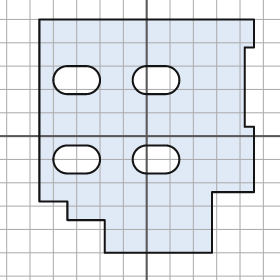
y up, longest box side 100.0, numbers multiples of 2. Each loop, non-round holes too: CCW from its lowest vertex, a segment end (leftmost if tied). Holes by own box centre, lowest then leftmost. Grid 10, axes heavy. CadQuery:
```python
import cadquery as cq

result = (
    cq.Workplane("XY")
    .moveTo(-18.0, -50.0)
    .lineTo(28.0, -50.0)
    .lineTo(28.0, -24.0)
    .lineTo(46.0, -24.0)
    .lineTo(46.0, 4.0)
    .lineTo(42.0, 4.0)
    .lineTo(42.0, 38.0)
    .lineTo(46.0, 38.0)
    .lineTo(46.0, 50.0)
    .lineTo(-46.0, 50.0)
    .lineTo(-46.0, -28.0)
    .lineTo(-34.0, -28.0)
    .lineTo(-34.0, -36.0)
    .lineTo(-18.0, -36.0)
    .close()
    .moveTo(-34.0, -16.0)
    .lineTo(-26.0, -16.0)
    .threePointArc((-20.0, -10.0), (-26.0, -4.0))
    .lineTo(-34.0, -4.0)
    .threePointArc((-40.0, -10.0), (-34.0, -16.0))
    .close()
    .moveTo(0.0, -16.0)
    .lineTo(8.0, -16.0)
    .threePointArc((14.0, -10.0), (8.0, -4.0))
    .lineTo(0.0, -4.0)
    .threePointArc((-6.0, -10.0), (0.0, -16.0))
    .close()
    .moveTo(-34.0, 18.0)
    .lineTo(-26.0, 18.0)
    .threePointArc((-20.0, 24.0), (-26.0, 30.0))
    .lineTo(-34.0, 30.0)
    .threePointArc((-40.0, 24.0), (-34.0, 18.0))
    .close()
    .moveTo(0.0, 18.0)
    .lineTo(8.0, 18.0)
    .threePointArc((14.0, 24.0), (8.0, 30.0))
    .lineTo(0.0, 30.0)
    .threePointArc((-6.0, 24.0), (0.0, 18.0))
    .close()
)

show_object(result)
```